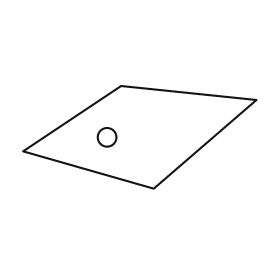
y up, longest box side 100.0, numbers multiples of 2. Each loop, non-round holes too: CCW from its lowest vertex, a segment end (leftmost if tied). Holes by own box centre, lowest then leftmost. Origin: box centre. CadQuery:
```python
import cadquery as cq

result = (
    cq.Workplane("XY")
    .moveTo(6.0, -22.0)
    .lineTo(50.0, 16.0)
    .lineTo(-8.0, 22.0)
    .lineTo(-50.0, -6.0)
    .close()
    .moveTo(-14.0, 0.0)
    .circle(4.0)
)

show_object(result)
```